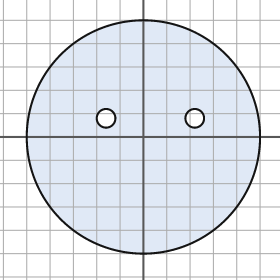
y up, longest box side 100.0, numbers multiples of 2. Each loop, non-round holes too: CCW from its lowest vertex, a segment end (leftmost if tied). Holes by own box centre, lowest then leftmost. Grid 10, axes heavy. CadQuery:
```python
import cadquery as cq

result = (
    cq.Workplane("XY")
    .moveTo(0.0, 0.0)
    .circle(50.0)
    .moveTo(-16.0, 8.0)
    .circle(4.0)
    .moveTo(22.0, 8.0)
    .circle(4.0)
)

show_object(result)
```